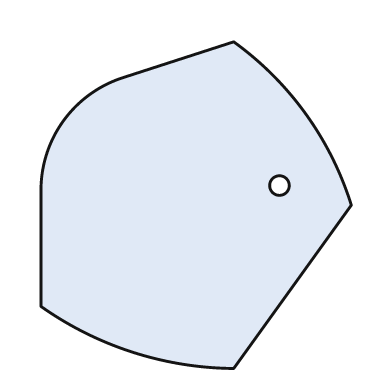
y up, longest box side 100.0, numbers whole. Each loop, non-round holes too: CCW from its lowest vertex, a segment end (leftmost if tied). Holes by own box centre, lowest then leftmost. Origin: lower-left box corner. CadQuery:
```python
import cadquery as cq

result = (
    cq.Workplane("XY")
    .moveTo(59.0, 0.0)
    .lineTo(95.0, 50.0)
    .threePointArc((81.0, 78.0), (59.0, 100.0))
    .lineTo(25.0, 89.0)
    .threePointArc((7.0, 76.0), (0.0, 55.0))
    .lineTo(0.0, 19.0)
    .threePointArc((28.0, 5.0), (59.0, 0.0))
    .close()
    .moveTo(73.0, 56.0)
    .circle(3.0)
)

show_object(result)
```